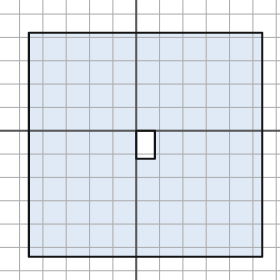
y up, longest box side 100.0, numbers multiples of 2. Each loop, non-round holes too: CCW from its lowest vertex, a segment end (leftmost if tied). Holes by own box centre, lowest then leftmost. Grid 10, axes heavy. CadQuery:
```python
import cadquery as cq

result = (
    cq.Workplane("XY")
    .moveTo(-46.0, -54.0)
    .lineTo(54.0, -54.0)
    .lineTo(54.0, 42.0)
    .lineTo(-46.0, 42.0)
    .close()
    .moveTo(0.0, -12.0)
    .lineTo(8.0, -12.0)
    .lineTo(8.0, 0.0)
    .lineTo(0.0, 0.0)
    .close()
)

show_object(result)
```